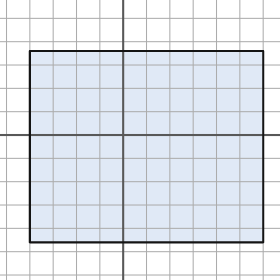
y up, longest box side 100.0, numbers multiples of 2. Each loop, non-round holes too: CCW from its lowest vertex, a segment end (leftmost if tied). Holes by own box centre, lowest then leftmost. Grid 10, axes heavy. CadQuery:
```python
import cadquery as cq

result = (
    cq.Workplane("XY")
    .moveTo(-40.0, -46.0)
    .lineTo(60.0, -46.0)
    .lineTo(60.0, 36.0)
    .lineTo(-40.0, 36.0)
    .close()
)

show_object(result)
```